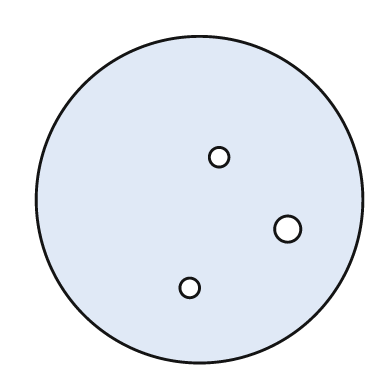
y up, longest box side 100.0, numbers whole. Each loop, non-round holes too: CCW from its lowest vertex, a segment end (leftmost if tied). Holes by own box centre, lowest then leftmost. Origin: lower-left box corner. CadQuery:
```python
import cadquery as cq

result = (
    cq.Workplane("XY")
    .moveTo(50.0, 50.0)
    .circle(50.0)
    .moveTo(47.0, 23.0)
    .circle(3.0)
    .moveTo(77.0, 41.0)
    .circle(4.0)
    .moveTo(56.0, 63.0)
    .circle(3.0)
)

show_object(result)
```